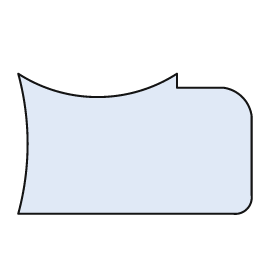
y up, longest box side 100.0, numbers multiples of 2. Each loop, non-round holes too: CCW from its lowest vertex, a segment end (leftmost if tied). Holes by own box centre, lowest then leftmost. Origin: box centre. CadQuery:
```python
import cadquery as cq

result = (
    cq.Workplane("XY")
    .moveTo(-50.0, -30.0)
    .lineTo(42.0, -30.0)
    .threePointArc((48.0, -28.0), (50.0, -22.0))
    .lineTo(50.0, 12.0)
    .threePointArc((46.0, 20.0), (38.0, 24.0))
    .lineTo(18.0, 24.0)
    .lineTo(18.0, 30.0)
    .threePointArc((-16.0, 20.0), (-50.0, 30.0))
    .threePointArc((-46.0, 0.0), (-50.0, -30.0))
    .close()
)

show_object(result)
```